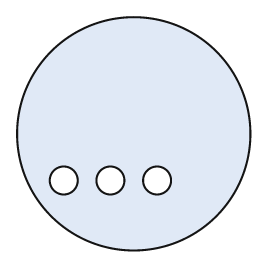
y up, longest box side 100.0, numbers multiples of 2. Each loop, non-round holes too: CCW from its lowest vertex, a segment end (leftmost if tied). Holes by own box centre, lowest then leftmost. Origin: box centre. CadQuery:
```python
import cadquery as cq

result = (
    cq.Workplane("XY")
    .moveTo(0.0, 0.0)
    .circle(50.0)
    .moveTo(-30.0, -20.0)
    .circle(6.0)
    .moveTo(-10.0, -20.0)
    .circle(6.0)
    .moveTo(10.0, -20.0)
    .circle(6.0)
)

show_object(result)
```